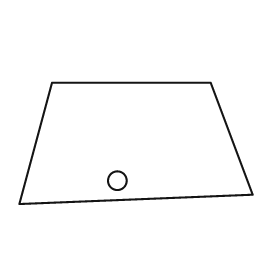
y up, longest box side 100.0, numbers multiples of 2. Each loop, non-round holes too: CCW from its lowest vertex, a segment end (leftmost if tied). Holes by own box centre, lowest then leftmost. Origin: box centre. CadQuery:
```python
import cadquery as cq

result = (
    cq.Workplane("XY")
    .moveTo(-50.0, -26.0)
    .lineTo(50.0, -22.0)
    .lineTo(32.0, 26.0)
    .lineTo(-36.0, 26.0)
    .close()
    .moveTo(-8.0, -16.0)
    .circle(4.0)
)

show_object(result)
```